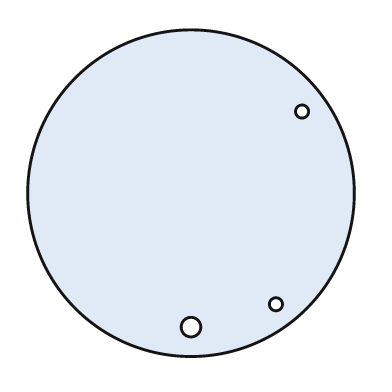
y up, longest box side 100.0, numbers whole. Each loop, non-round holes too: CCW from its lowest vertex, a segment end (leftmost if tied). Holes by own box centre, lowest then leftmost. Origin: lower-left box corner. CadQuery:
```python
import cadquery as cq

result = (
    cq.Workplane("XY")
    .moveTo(50.0, 50.0)
    .circle(50.0)
    .moveTo(50.0, 9.0)
    .circle(3.0)
    .moveTo(76.0, 16.0)
    .circle(2.0)
    .moveTo(84.0, 75.0)
    .circle(2.0)
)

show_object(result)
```